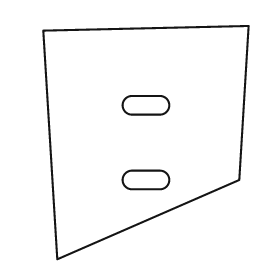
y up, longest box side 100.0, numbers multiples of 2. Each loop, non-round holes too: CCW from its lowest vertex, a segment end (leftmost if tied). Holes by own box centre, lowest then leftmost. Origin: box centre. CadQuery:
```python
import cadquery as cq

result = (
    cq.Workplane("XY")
    .moveTo(-38.0, -50.0)
    .lineTo(40.0, -16.0)
    .lineTo(44.0, 50.0)
    .lineTo(-44.0, 48.0)
    .close()
    .moveTo(-6.0, -20.0)
    .lineTo(6.0, -20.0)
    .threePointArc((10.0, -16.0), (6.0, -12.0))
    .lineTo(-6.0, -12.0)
    .threePointArc((-10.0, -16.0), (-6.0, -20.0))
    .close()
    .moveTo(-6.0, 12.0)
    .lineTo(6.0, 12.0)
    .threePointArc((10.0, 16.0), (6.0, 20.0))
    .lineTo(-6.0, 20.0)
    .threePointArc((-10.0, 16.0), (-6.0, 12.0))
    .close()
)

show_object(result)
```